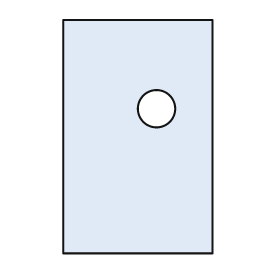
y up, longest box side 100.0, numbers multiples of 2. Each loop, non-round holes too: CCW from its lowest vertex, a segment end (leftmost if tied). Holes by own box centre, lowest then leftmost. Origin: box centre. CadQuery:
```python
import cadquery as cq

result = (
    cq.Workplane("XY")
    .moveTo(-32.0, -50.0)
    .lineTo(32.0, -50.0)
    .lineTo(32.0, 50.0)
    .lineTo(-32.0, 50.0)
    .close()
    .moveTo(8.0, 12.0)
    .circle(8.0)
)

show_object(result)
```